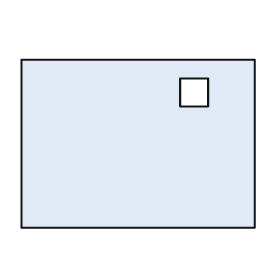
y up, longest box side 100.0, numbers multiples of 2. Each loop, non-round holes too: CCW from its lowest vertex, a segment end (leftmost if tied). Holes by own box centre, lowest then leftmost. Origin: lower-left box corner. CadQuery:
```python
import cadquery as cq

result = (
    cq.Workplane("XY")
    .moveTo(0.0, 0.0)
    .lineTo(100.0, 0.0)
    .lineTo(100.0, 72.0)
    .lineTo(0.0, 72.0)
    .close()
    .moveTo(68.0, 52.0)
    .lineTo(80.0, 52.0)
    .lineTo(80.0, 64.0)
    .lineTo(68.0, 64.0)
    .close()
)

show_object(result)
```